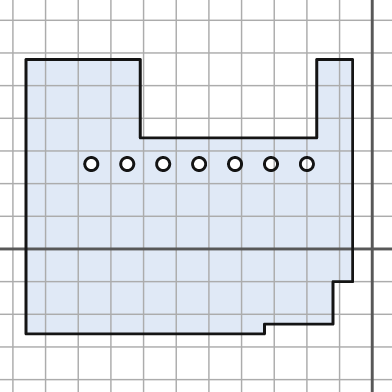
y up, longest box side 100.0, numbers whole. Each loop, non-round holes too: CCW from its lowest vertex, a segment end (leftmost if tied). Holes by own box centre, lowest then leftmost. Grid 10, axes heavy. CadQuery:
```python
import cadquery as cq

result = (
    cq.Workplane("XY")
    .moveTo(-106.0, -26.0)
    .lineTo(-33.0, -26.0)
    .lineTo(-33.0, -23.0)
    .lineTo(-12.0, -23.0)
    .lineTo(-12.0, -10.0)
    .lineTo(-6.0, -10.0)
    .lineTo(-6.0, 58.0)
    .lineTo(-17.0, 58.0)
    .lineTo(-17.0, 34.0)
    .lineTo(-71.0, 34.0)
    .lineTo(-71.0, 58.0)
    .lineTo(-106.0, 58.0)
    .close()
    .moveTo(-86.0, 26.0)
    .circle(2.0)
    .moveTo(-75.0, 26.0)
    .circle(2.0)
    .moveTo(-64.0, 26.0)
    .circle(2.0)
    .moveTo(-53.0, 26.0)
    .circle(2.0)
    .moveTo(-42.0, 26.0)
    .circle(2.0)
    .moveTo(-31.0, 26.0)
    .circle(2.0)
    .moveTo(-20.0, 26.0)
    .circle(2.0)
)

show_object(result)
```